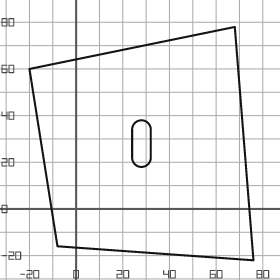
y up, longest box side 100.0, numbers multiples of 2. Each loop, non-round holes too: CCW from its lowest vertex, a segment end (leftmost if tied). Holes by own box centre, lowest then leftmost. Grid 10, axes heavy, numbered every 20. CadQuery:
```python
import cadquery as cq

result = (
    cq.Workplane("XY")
    .moveTo(76.0, -22.0)
    .lineTo(68.0, 78.0)
    .lineTo(-20.0, 60.0)
    .lineTo(-8.0, -16.0)
    .close()
    .moveTo(24.0, 22.0)
    .threePointArc((28.0, 18.0), (32.0, 22.0))
    .lineTo(32.0, 34.0)
    .threePointArc((28.0, 38.0), (24.0, 34.0))
    .close()
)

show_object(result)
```